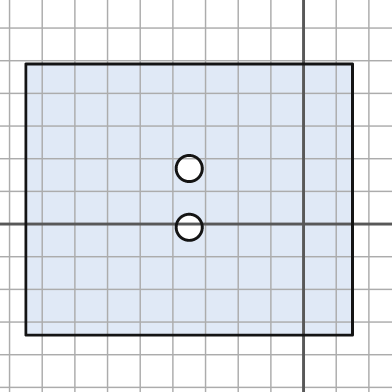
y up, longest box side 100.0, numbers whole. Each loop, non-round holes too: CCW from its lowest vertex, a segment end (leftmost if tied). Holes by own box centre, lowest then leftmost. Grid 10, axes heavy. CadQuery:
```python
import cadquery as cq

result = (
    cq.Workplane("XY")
    .moveTo(-85.0, -34.0)
    .lineTo(15.0, -34.0)
    .lineTo(15.0, 49.0)
    .lineTo(-85.0, 49.0)
    .close()
    .moveTo(-35.0, -1.0)
    .circle(4.0)
    .moveTo(-35.0, 17.0)
    .circle(4.0)
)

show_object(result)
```